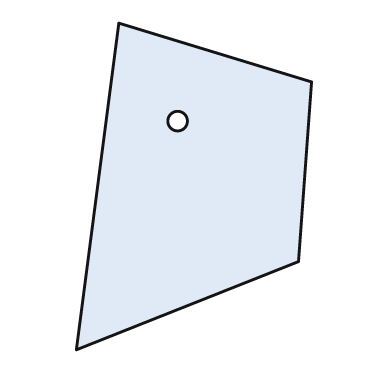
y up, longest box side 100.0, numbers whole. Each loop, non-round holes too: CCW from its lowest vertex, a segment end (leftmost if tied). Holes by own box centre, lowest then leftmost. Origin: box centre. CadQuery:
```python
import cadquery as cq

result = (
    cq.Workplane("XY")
    .moveTo(-36.0, -50.0)
    .lineTo(32.0, -23.0)
    .lineTo(36.0, 32.0)
    .lineTo(-23.0, 50.0)
    .close()
    .moveTo(-5.0, 20.0)
    .circle(3.0)
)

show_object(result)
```